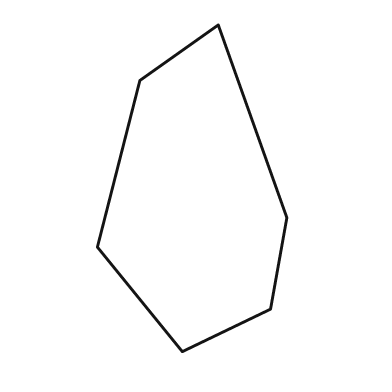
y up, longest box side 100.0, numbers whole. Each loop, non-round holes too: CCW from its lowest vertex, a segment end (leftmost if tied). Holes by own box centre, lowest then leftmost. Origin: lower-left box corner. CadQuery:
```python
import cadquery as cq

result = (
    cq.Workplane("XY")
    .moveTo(26.0, 0.0)
    .lineTo(53.0, 13.0)
    .lineTo(58.0, 41.0)
    .lineTo(37.0, 100.0)
    .lineTo(13.0, 83.0)
    .lineTo(0.0, 32.0)
    .close()
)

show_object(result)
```